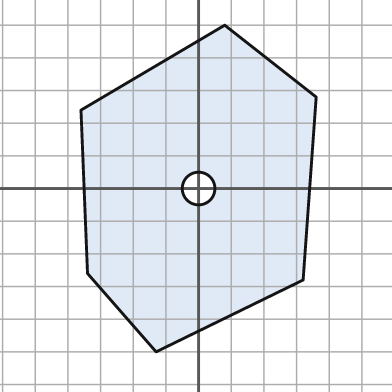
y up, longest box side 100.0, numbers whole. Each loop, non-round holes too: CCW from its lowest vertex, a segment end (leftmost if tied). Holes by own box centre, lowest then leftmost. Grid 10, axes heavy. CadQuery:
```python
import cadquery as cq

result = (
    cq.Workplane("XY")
    .moveTo(-13.0, -50.0)
    .lineTo(32.0, -28.0)
    .lineTo(36.0, 28.0)
    .lineTo(8.0, 50.0)
    .lineTo(-36.0, 24.0)
    .lineTo(-34.0, -26.0)
    .close()
    .moveTo(0.0, 0.0)
    .circle(5.0)
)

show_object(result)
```